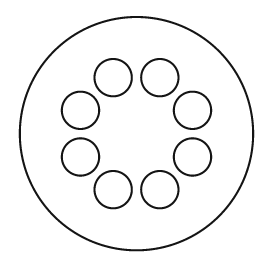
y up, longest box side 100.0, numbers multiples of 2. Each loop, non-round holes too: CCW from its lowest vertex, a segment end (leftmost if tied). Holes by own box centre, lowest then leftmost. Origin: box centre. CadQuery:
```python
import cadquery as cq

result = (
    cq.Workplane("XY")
    .moveTo(0.0, 0.0)
    .circle(50.0)
    .moveTo(-10.0, -24.0)
    .circle(8.0)
    .moveTo(10.0, -24.0)
    .circle(8.0)
    .moveTo(-24.0, -10.0)
    .circle(8.0)
    .moveTo(24.0, -10.0)
    .circle(8.0)
    .moveTo(-24.0, 10.0)
    .circle(8.0)
    .moveTo(24.0, 10.0)
    .circle(8.0)
    .moveTo(-10.0, 24.0)
    .circle(8.0)
    .moveTo(10.0, 24.0)
    .circle(8.0)
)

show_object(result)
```